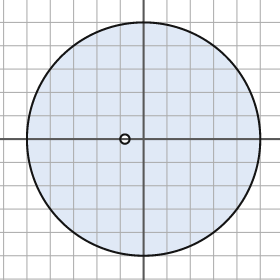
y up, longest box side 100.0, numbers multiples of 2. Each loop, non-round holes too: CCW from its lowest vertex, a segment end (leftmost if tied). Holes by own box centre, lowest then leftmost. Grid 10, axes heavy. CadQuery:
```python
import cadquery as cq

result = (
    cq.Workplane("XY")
    .moveTo(0.0, 0.0)
    .circle(50.0)
    .moveTo(-8.0, 0.0)
    .circle(2.0)
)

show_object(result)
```